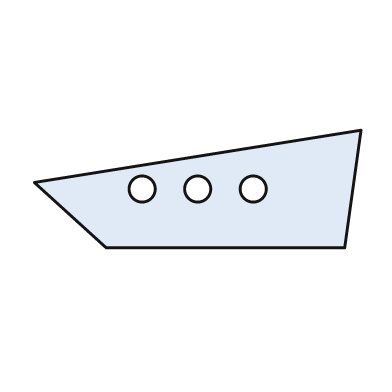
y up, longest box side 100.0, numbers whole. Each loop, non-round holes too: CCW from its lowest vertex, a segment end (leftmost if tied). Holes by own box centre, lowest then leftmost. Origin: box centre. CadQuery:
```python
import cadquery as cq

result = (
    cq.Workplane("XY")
    .moveTo(-28.0, -18.0)
    .lineTo(45.0, -18.0)
    .lineTo(50.0, 18.0)
    .lineTo(-50.0, 2.0)
    .close()
    .moveTo(-17.0, 0.0)
    .circle(4.0)
    .moveTo(0.0, 0.0)
    .circle(4.0)
    .moveTo(17.0, 0.0)
    .circle(4.0)
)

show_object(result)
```